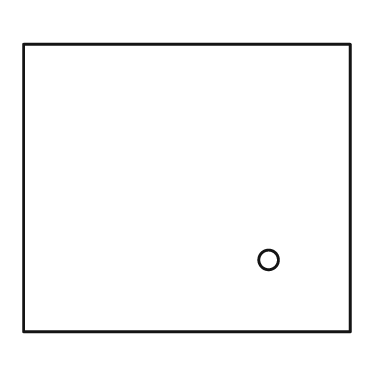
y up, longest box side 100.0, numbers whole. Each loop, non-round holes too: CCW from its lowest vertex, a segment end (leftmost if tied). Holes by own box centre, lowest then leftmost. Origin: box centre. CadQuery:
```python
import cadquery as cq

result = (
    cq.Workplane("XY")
    .moveTo(-50.0, -44.0)
    .lineTo(50.0, -44.0)
    .lineTo(50.0, 44.0)
    .lineTo(-50.0, 44.0)
    .close()
    .moveTo(25.0, -22.0)
    .circle(3.0)
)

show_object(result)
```